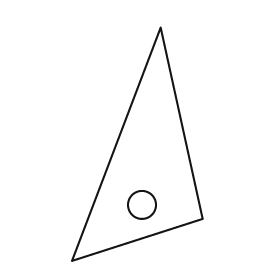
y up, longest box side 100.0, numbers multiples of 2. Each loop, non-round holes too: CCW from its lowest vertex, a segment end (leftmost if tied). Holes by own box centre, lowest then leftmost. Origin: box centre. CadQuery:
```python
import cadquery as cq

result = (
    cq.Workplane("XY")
    .moveTo(-28.0, -50.0)
    .lineTo(28.0, -32.0)
    .lineTo(10.0, 50.0)
    .close()
    .moveTo(2.0, -26.0)
    .circle(6.0)
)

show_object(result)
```